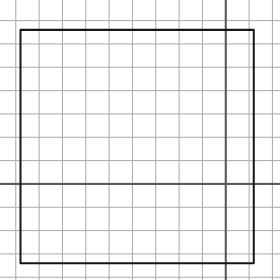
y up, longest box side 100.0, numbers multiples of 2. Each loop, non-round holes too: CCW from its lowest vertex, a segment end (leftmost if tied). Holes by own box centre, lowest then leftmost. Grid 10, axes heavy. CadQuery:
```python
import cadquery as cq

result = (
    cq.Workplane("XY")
    .moveTo(-88.0, -34.0)
    .lineTo(12.0, -34.0)
    .lineTo(12.0, 66.0)
    .lineTo(-88.0, 66.0)
    .close()
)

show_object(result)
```